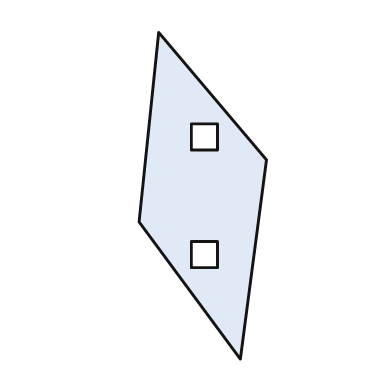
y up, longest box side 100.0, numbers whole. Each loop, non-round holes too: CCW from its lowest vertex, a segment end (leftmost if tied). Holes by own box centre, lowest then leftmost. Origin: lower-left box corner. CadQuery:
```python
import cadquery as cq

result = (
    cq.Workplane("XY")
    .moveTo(31.0, 0.0)
    .lineTo(39.0, 61.0)
    .lineTo(6.0, 100.0)
    .lineTo(0.0, 42.0)
    .close()
    .moveTo(16.0, 28.0)
    .lineTo(24.0, 28.0)
    .lineTo(24.0, 36.0)
    .lineTo(16.0, 36.0)
    .close()
    .moveTo(16.0, 64.0)
    .lineTo(24.0, 64.0)
    .lineTo(24.0, 72.0)
    .lineTo(16.0, 72.0)
    .close()
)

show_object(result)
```